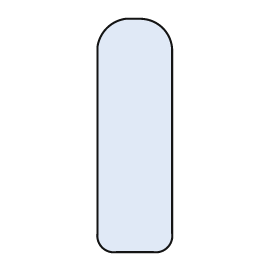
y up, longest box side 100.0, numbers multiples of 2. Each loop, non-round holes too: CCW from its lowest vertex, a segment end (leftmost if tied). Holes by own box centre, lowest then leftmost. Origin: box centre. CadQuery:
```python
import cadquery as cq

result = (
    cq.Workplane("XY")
    .moveTo(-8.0, -50.0)
    .lineTo(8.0, -50.0)
    .threePointArc((14.0, -48.0), (16.0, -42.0))
    .lineTo(16.0, 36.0)
    .threePointArc((12.0, 46.0), (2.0, 50.0))
    .lineTo(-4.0, 50.0)
    .threePointArc((-12.0, 46.0), (-16.0, 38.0))
    .lineTo(-16.0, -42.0)
    .threePointArc((-14.0, -48.0), (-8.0, -50.0))
    .close()
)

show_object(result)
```